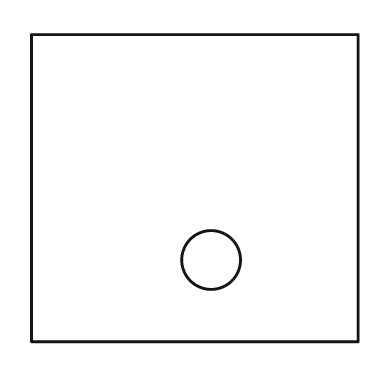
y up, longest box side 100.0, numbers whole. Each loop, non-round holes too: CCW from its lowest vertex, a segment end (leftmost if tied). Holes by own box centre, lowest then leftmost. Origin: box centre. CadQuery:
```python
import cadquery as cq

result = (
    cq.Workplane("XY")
    .moveTo(-50.0, -47.0)
    .lineTo(50.0, -47.0)
    .lineTo(50.0, 47.0)
    .lineTo(-50.0, 47.0)
    .close()
    .moveTo(5.0, -22.0)
    .circle(9.0)
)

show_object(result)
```